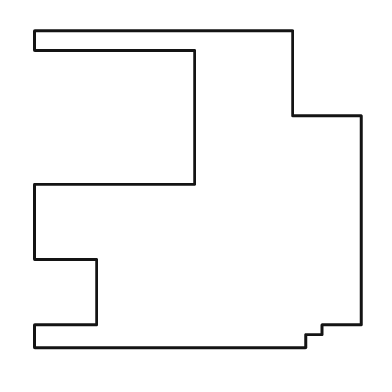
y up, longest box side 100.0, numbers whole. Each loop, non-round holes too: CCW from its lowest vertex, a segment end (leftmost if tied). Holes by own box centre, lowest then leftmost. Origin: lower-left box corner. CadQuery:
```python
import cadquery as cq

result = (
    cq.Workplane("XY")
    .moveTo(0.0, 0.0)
    .lineTo(83.0, 0.0)
    .lineTo(83.0, 4.0)
    .lineTo(88.0, 4.0)
    .lineTo(88.0, 7.0)
    .lineTo(100.0, 7.0)
    .lineTo(100.0, 71.0)
    .lineTo(79.0, 71.0)
    .lineTo(79.0, 97.0)
    .lineTo(0.0, 97.0)
    .lineTo(0.0, 91.0)
    .lineTo(49.0, 91.0)
    .lineTo(49.0, 50.0)
    .lineTo(0.0, 50.0)
    .lineTo(0.0, 27.0)
    .lineTo(19.0, 27.0)
    .lineTo(19.0, 7.0)
    .lineTo(0.0, 7.0)
    .close()
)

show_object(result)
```